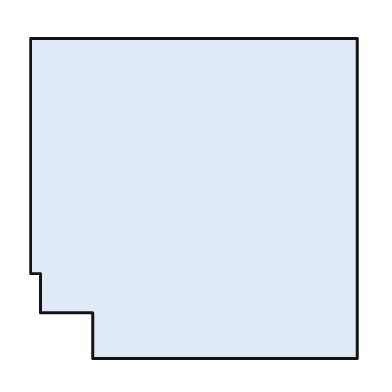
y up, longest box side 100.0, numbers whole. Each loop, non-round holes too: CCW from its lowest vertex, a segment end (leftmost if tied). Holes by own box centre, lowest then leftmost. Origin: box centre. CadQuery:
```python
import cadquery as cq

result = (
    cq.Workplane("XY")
    .moveTo(-31.0, -49.0)
    .lineTo(50.0, -49.0)
    .lineTo(50.0, 49.0)
    .lineTo(-50.0, 49.0)
    .lineTo(-50.0, -23.0)
    .lineTo(-47.0, -23.0)
    .lineTo(-47.0, -35.0)
    .lineTo(-31.0, -35.0)
    .close()
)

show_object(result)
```